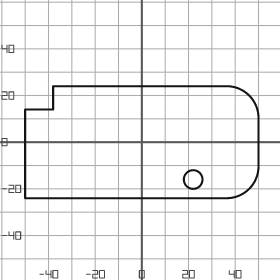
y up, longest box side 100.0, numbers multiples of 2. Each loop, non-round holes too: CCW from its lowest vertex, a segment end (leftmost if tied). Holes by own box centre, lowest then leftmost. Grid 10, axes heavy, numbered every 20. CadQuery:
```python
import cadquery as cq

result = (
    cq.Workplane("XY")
    .moveTo(-50.0, -24.0)
    .lineTo(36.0, -24.0)
    .threePointArc((46.0, -20.0), (50.0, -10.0))
    .lineTo(50.0, 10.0)
    .threePointArc((46.0, 20.0), (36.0, 24.0))
    .lineTo(-38.0, 24.0)
    .lineTo(-38.0, 14.0)
    .lineTo(-50.0, 14.0)
    .close()
    .moveTo(22.0, -16.0)
    .circle(4.0)
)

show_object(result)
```